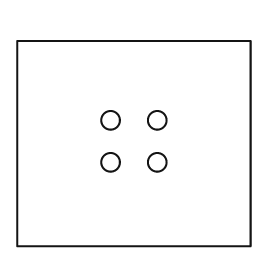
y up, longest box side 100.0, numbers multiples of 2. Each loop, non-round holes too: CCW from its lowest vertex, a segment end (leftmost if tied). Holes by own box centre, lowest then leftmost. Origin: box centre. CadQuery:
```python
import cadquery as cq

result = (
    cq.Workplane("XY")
    .moveTo(-50.0, -44.0)
    .lineTo(50.0, -44.0)
    .lineTo(50.0, 44.0)
    .lineTo(-50.0, 44.0)
    .close()
    .moveTo(-10.0, -8.0)
    .circle(4.0)
    .moveTo(10.0, -8.0)
    .circle(4.0)
    .moveTo(-10.0, 10.0)
    .circle(4.0)
    .moveTo(10.0, 10.0)
    .circle(4.0)
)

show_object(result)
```